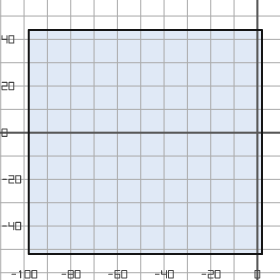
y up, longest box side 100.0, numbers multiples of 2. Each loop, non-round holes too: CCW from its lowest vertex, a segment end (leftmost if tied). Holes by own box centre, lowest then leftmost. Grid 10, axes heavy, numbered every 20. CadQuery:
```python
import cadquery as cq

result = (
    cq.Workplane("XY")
    .moveTo(-98.0, -52.0)
    .lineTo(2.0, -52.0)
    .lineTo(2.0, 44.0)
    .lineTo(-98.0, 44.0)
    .close()
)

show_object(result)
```